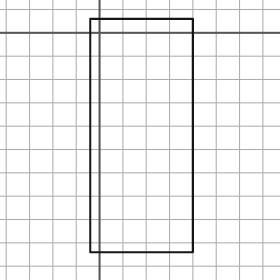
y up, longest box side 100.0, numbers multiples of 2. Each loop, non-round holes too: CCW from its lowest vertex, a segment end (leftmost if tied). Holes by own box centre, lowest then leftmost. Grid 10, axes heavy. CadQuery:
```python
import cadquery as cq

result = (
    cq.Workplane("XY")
    .moveTo(-4.0, -94.0)
    .lineTo(40.0, -94.0)
    .lineTo(40.0, 6.0)
    .lineTo(-4.0, 6.0)
    .close()
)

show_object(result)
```